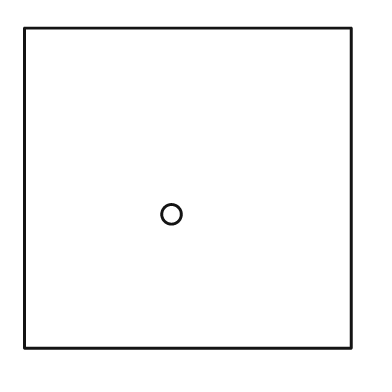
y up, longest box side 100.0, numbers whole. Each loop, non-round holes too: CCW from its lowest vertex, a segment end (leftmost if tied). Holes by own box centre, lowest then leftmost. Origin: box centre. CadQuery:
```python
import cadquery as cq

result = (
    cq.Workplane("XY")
    .moveTo(-50.0, -49.0)
    .lineTo(50.0, -49.0)
    .lineTo(50.0, 49.0)
    .lineTo(-50.0, 49.0)
    .close()
    .moveTo(-5.0, -8.0)
    .circle(3.0)
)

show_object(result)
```